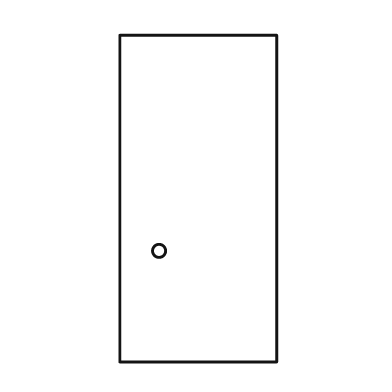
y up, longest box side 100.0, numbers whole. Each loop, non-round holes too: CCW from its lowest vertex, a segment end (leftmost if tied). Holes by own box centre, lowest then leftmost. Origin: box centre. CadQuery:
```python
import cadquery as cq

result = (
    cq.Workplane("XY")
    .moveTo(-24.0, -50.0)
    .lineTo(24.0, -50.0)
    .lineTo(24.0, 50.0)
    .lineTo(-24.0, 50.0)
    .close()
    .moveTo(-12.0, -16.0)
    .circle(2.0)
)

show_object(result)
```